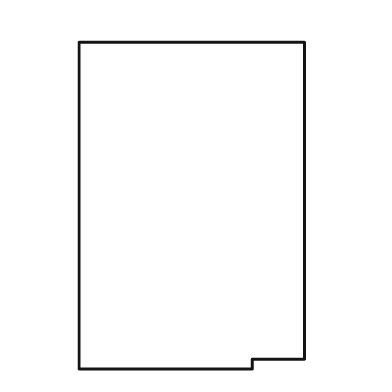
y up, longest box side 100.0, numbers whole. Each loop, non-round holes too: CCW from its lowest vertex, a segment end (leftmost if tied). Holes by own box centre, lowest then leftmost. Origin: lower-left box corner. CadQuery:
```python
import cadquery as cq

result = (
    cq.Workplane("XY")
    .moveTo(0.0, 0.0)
    .lineTo(53.0, 0.0)
    .lineTo(53.0, 3.0)
    .lineTo(69.0, 3.0)
    .lineTo(69.0, 100.0)
    .lineTo(0.0, 100.0)
    .close()
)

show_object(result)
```